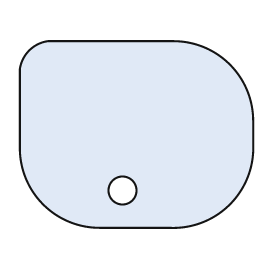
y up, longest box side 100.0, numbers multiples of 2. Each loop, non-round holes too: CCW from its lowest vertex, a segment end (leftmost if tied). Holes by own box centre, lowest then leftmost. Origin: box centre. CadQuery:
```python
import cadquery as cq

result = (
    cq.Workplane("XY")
    .moveTo(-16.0, -40.0)
    .lineTo(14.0, -40.0)
    .threePointArc((40.0, -30.0), (50.0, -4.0))
    .lineTo(50.0, 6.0)
    .threePointArc((40.0, 30.0), (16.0, 40.0))
    .lineTo(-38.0, 40.0)
    .threePointArc((-46.0, 36.0), (-50.0, 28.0))
    .lineTo(-50.0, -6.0)
    .threePointArc((-40.0, -30.0), (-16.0, -40.0))
    .close()
    .moveTo(-6.0, -24.0)
    .circle(6.0)
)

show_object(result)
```